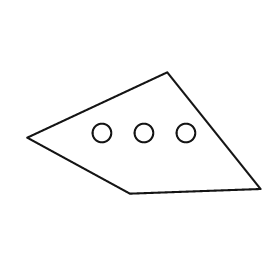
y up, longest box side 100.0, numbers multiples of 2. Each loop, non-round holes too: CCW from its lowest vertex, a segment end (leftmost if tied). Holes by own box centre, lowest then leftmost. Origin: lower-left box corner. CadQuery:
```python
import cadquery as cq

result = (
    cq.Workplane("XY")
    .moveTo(44.0, 0.0)
    .lineTo(100.0, 2.0)
    .lineTo(60.0, 52.0)
    .lineTo(0.0, 24.0)
    .close()
    .moveTo(32.0, 26.0)
    .circle(4.0)
    .moveTo(50.0, 26.0)
    .circle(4.0)
    .moveTo(68.0, 26.0)
    .circle(4.0)
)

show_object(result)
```